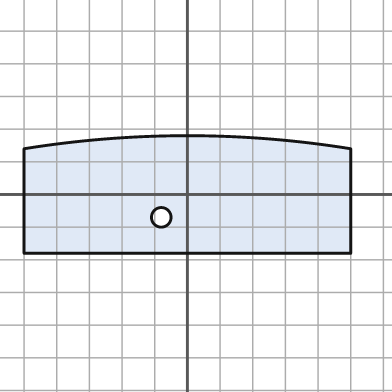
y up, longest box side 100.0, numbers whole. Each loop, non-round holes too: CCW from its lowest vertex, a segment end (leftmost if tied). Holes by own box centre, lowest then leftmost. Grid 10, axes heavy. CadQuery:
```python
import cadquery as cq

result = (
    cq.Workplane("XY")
    .moveTo(-50.0, -18.0)
    .lineTo(50.0, -18.0)
    .lineTo(50.0, 14.0)
    .threePointArc((0.0, 18.0), (-50.0, 14.0))
    .close()
    .moveTo(-8.0, -7.0)
    .circle(3.0)
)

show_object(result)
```